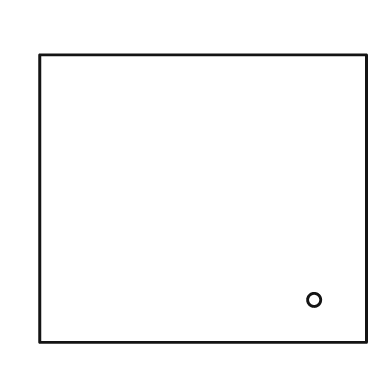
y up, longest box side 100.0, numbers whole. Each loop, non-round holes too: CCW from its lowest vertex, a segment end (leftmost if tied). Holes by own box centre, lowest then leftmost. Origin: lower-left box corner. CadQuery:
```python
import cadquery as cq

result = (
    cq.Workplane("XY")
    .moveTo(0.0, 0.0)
    .lineTo(100.0, 0.0)
    .lineTo(100.0, 88.0)
    .lineTo(0.0, 88.0)
    .close()
    .moveTo(84.0, 13.0)
    .circle(2.0)
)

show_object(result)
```